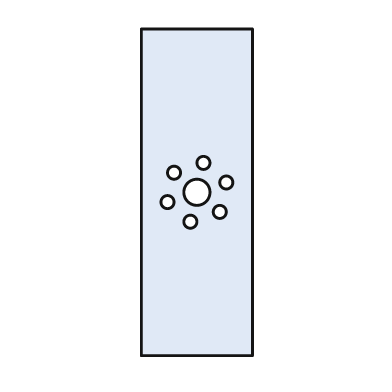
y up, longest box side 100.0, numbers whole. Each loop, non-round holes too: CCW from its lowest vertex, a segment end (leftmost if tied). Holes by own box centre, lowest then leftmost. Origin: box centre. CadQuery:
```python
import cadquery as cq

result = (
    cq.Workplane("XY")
    .moveTo(-17.0, -50.0)
    .lineTo(17.0, -50.0)
    .lineTo(17.0, 50.0)
    .lineTo(-17.0, 50.0)
    .close()
    .moveTo(-2.0, -9.0)
    .circle(2.0)
    .moveTo(7.0, -6.0)
    .circle(2.0)
    .moveTo(-9.0, -3.0)
    .circle(2.0)
    .moveTo(0.0, 0.0)
    .circle(4.0)
    .moveTo(9.0, 3.0)
    .circle(2.0)
    .moveTo(-7.0, 6.0)
    .circle(2.0)
    .moveTo(2.0, 9.0)
    .circle(2.0)
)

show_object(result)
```